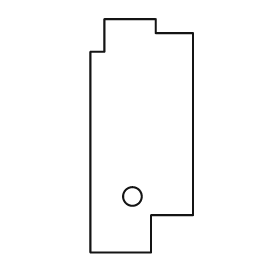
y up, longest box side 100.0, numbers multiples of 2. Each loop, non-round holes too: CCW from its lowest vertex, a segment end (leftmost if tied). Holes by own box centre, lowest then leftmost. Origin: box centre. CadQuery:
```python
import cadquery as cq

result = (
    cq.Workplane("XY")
    .moveTo(-22.0, -50.0)
    .lineTo(4.0, -50.0)
    .lineTo(4.0, -34.0)
    .lineTo(22.0, -34.0)
    .lineTo(22.0, 44.0)
    .lineTo(6.0, 44.0)
    .lineTo(6.0, 50.0)
    .lineTo(-16.0, 50.0)
    .lineTo(-16.0, 36.0)
    .lineTo(-22.0, 36.0)
    .close()
    .moveTo(-4.0, -26.0)
    .circle(4.0)
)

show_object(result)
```